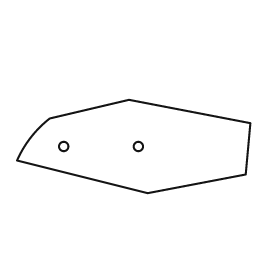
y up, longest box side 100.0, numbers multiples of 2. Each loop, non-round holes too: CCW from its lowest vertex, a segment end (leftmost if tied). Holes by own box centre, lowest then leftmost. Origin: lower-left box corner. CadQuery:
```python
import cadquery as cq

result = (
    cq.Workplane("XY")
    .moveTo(56.0, 0.0)
    .lineTo(98.0, 8.0)
    .lineTo(100.0, 30.0)
    .lineTo(48.0, 40.0)
    .lineTo(14.0, 32.0)
    .threePointArc((6.0, 24.0), (0.0, 14.0))
    .close()
    .moveTo(20.0, 20.0)
    .circle(2.0)
    .moveTo(52.0, 20.0)
    .circle(2.0)
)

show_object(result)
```